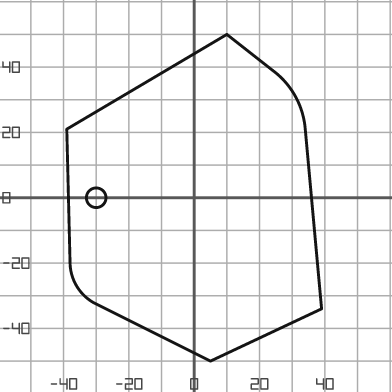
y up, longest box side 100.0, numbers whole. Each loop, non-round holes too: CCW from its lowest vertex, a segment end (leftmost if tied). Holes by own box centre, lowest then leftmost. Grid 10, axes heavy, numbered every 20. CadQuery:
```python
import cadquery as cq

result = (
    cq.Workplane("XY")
    .moveTo(5.0, -50.0)
    .lineTo(39.0, -34.0)
    .lineTo(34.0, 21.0)
    .threePointArc((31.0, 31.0), (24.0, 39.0))
    .lineTo(10.0, 50.0)
    .lineTo(-39.0, 21.0)
    .lineTo(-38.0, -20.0)
    .threePointArc((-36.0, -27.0), (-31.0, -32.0))
    .close()
    .moveTo(-30.0, 0.0)
    .circle(3.0)
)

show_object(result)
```